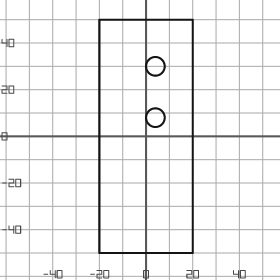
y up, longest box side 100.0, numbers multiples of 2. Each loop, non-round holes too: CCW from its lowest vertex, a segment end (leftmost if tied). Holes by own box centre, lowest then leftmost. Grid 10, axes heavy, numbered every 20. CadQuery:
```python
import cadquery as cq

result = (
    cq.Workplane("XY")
    .moveTo(-20.0, -50.0)
    .lineTo(20.0, -50.0)
    .lineTo(20.0, 50.0)
    .lineTo(-20.0, 50.0)
    .close()
    .moveTo(4.0, 8.0)
    .circle(4.0)
    .moveTo(4.0, 30.0)
    .circle(4.0)
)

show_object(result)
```